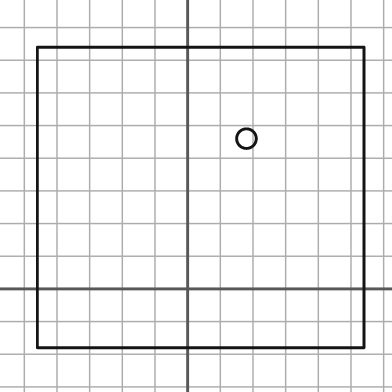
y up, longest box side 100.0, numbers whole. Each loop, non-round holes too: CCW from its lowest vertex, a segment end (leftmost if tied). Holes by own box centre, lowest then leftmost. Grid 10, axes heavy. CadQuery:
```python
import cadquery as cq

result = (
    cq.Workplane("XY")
    .moveTo(-46.0, -18.0)
    .lineTo(54.0, -18.0)
    .lineTo(54.0, 74.0)
    .lineTo(-46.0, 74.0)
    .close()
    .moveTo(18.0, 46.0)
    .circle(3.0)
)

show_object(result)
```